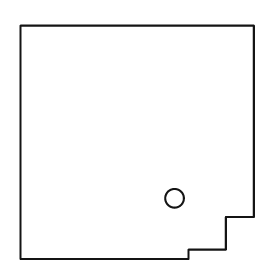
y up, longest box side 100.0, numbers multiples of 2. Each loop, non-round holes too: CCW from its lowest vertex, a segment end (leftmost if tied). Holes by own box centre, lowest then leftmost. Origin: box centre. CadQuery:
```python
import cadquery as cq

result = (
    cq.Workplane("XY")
    .moveTo(-50.0, -50.0)
    .lineTo(22.0, -50.0)
    .lineTo(22.0, -46.0)
    .lineTo(38.0, -46.0)
    .lineTo(38.0, -32.0)
    .lineTo(50.0, -32.0)
    .lineTo(50.0, 50.0)
    .lineTo(-50.0, 50.0)
    .close()
    .moveTo(16.0, -24.0)
    .circle(4.0)
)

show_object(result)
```